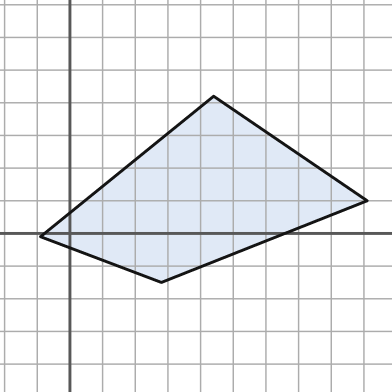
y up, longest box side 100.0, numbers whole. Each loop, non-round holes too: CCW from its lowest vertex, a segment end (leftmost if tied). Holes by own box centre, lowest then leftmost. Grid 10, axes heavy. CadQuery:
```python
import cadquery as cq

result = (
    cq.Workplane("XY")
    .moveTo(28.0, -15.0)
    .lineTo(91.0, 10.0)
    .lineTo(44.0, 42.0)
    .lineTo(-9.0, -1.0)
    .close()
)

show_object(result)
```